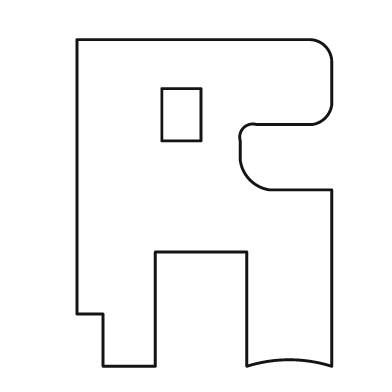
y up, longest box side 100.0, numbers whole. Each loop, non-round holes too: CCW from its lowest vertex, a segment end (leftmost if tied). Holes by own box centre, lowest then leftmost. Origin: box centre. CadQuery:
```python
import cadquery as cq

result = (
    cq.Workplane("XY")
    .moveTo(-31.0, -50.0)
    .lineTo(-15.0, -50.0)
    .lineTo(-15.0, -15.0)
    .lineTo(13.0, -15.0)
    .lineTo(13.0, -50.0)
    .threePointArc((26.0, -48.0), (39.0, -50.0))
    .lineTo(39.0, 4.0)
    .lineTo(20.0, 4.0)
    .threePointArc((14.0, 7.0), (11.0, 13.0))
    .lineTo(11.0, 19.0)
    .threePointArc((12.0, 23.0), (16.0, 24.0))
    .lineTo(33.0, 24.0)
    .threePointArc((37.0, 26.0), (39.0, 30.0))
    .lineTo(39.0, 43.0)
    .threePointArc((37.0, 48.0), (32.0, 50.0))
    .lineTo(-39.0, 50.0)
    .lineTo(-39.0, -34.0)
    .lineTo(-31.0, -34.0)
    .close()
    .moveTo(-13.0, 19.0)
    .lineTo(-1.0, 19.0)
    .lineTo(-1.0, 35.0)
    .lineTo(-13.0, 35.0)
    .close()
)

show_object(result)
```